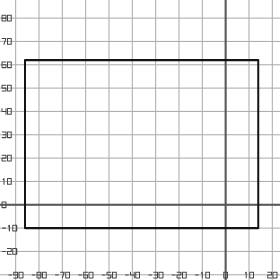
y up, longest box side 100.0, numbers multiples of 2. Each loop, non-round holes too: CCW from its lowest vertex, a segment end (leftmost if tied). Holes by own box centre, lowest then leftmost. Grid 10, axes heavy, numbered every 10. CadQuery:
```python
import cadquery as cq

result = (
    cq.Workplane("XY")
    .moveTo(-86.0, -10.0)
    .lineTo(14.0, -10.0)
    .lineTo(14.0, 62.0)
    .lineTo(-86.0, 62.0)
    .close()
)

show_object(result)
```